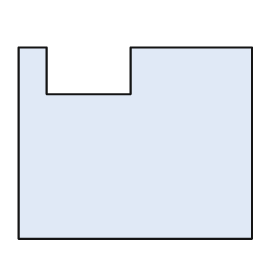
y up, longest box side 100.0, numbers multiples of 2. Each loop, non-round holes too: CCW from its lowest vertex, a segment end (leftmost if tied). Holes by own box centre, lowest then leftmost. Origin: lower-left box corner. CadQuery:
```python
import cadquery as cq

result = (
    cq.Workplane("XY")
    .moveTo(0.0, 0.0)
    .lineTo(100.0, 0.0)
    .lineTo(100.0, 82.0)
    .lineTo(48.0, 82.0)
    .lineTo(48.0, 62.0)
    .lineTo(12.0, 62.0)
    .lineTo(12.0, 82.0)
    .lineTo(0.0, 82.0)
    .close()
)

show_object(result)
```